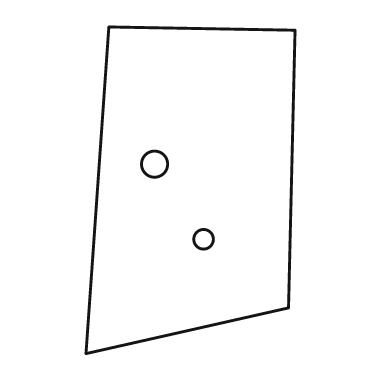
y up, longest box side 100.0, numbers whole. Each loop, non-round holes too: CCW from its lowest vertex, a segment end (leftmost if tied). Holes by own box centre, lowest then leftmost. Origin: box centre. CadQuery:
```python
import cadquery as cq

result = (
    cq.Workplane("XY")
    .moveTo(-32.0, -50.0)
    .lineTo(30.0, -36.0)
    .lineTo(32.0, 49.0)
    .lineTo(-25.0, 50.0)
    .close()
    .moveTo(4.0, -15.0)
    .circle(3.0)
    .moveTo(-11.0, 8.0)
    .circle(4.0)
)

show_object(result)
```